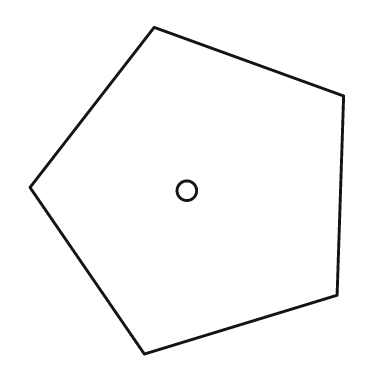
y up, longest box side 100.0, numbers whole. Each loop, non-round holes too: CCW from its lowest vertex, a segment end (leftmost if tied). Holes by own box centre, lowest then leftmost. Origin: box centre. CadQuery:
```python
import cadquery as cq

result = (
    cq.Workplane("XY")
    .moveTo(-13.0, -50.0)
    .lineTo(46.0, -32.0)
    .lineTo(48.0, 29.0)
    .lineTo(-10.0, 50.0)
    .lineTo(-48.0, 1.0)
    .close()
    .moveTo(0.0, 0.0)
    .circle(3.0)
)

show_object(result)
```